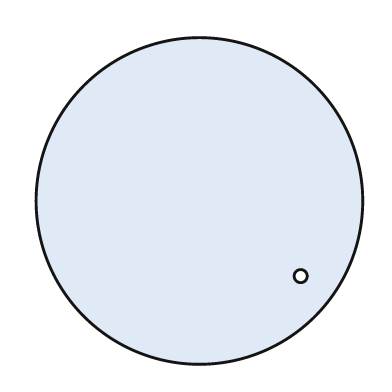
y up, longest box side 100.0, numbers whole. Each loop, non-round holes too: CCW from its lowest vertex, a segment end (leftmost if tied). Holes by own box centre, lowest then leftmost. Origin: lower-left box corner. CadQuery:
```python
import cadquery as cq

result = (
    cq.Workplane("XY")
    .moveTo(50.0, 50.0)
    .circle(50.0)
    .moveTo(81.0, 27.0)
    .circle(2.0)
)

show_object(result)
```